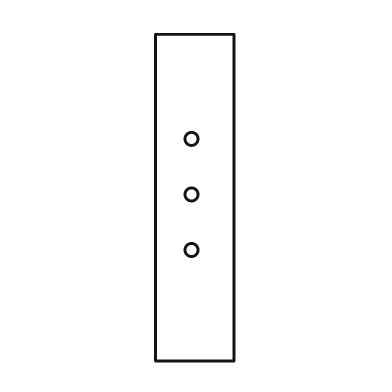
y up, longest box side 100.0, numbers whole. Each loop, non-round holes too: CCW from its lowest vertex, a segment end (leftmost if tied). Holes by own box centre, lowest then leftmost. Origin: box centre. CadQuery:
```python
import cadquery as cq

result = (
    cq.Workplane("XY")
    .moveTo(-12.0, -50.0)
    .lineTo(12.0, -50.0)
    .lineTo(12.0, 50.0)
    .lineTo(-12.0, 50.0)
    .close()
    .moveTo(-1.0, -16.0)
    .circle(2.0)
    .moveTo(-1.0, 1.0)
    .circle(2.0)
    .moveTo(-1.0, 18.0)
    .circle(2.0)
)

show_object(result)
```